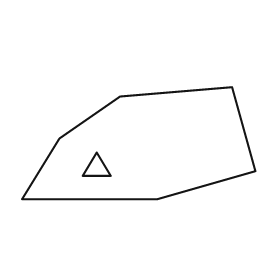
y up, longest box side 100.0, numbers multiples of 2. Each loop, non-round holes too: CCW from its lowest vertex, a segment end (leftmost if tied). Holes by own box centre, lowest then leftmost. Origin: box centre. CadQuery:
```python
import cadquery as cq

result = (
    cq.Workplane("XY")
    .moveTo(-50.0, -24.0)
    .lineTo(8.0, -24.0)
    .lineTo(50.0, -12.0)
    .lineTo(40.0, 24.0)
    .lineTo(-8.0, 20.0)
    .lineTo(-34.0, 2.0)
    .close()
    .moveTo(-24.0, -14.0)
    .lineTo(-12.0, -14.0)
    .lineTo(-18.0, -4.0)
    .close()
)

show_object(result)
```